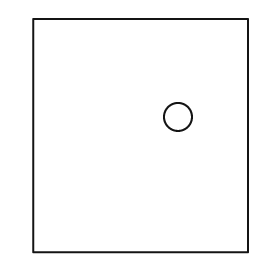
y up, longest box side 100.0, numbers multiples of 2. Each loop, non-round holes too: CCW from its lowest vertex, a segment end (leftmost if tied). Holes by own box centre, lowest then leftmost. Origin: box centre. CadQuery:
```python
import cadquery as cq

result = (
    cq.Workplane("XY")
    .moveTo(-46.0, -50.0)
    .lineTo(46.0, -50.0)
    .lineTo(46.0, 50.0)
    .lineTo(-46.0, 50.0)
    .close()
    .moveTo(16.0, 8.0)
    .circle(6.0)
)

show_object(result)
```